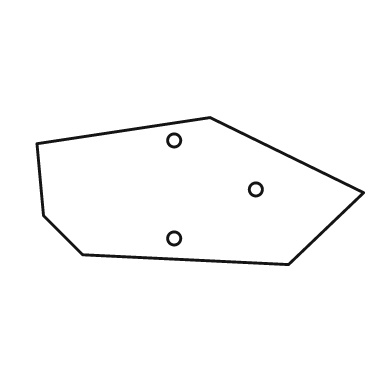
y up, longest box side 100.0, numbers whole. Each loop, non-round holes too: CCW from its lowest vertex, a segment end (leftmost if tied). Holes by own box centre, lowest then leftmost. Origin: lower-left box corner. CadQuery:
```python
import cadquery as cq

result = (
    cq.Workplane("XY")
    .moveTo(77.0, 0.0)
    .lineTo(100.0, 22.0)
    .lineTo(53.0, 45.0)
    .lineTo(0.0, 37.0)
    .lineTo(2.0, 15.0)
    .lineTo(14.0, 3.0)
    .close()
    .moveTo(42.0, 8.0)
    .circle(2.0)
    .moveTo(67.0, 23.0)
    .circle(2.0)
    .moveTo(42.0, 38.0)
    .circle(2.0)
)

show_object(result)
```